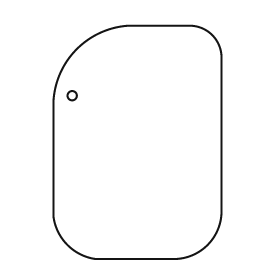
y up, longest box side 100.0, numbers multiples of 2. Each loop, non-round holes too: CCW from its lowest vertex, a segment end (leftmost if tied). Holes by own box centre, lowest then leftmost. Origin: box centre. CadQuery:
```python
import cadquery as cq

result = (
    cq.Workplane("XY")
    .moveTo(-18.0, -50.0)
    .lineTo(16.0, -50.0)
    .threePointArc((30.0, -44.0), (36.0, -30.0))
    .lineTo(36.0, 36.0)
    .threePointArc((32.0, 46.0), (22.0, 50.0))
    .lineTo(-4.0, 50.0)
    .threePointArc((-26.0, 40.0), (-36.0, 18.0))
    .lineTo(-36.0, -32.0)
    .threePointArc((-30.0, -44.0), (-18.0, -50.0))
    .close()
    .moveTo(-28.0, 20.0)
    .circle(2.0)
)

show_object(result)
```